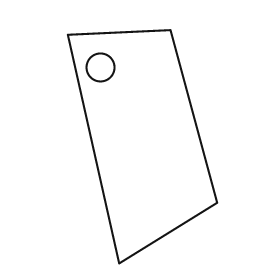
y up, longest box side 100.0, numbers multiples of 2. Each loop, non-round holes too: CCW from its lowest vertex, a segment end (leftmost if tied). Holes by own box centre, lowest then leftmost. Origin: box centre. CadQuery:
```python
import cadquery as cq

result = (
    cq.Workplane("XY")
    .moveTo(-10.0, -50.0)
    .lineTo(32.0, -24.0)
    .lineTo(12.0, 50.0)
    .lineTo(-32.0, 48.0)
    .close()
    .moveTo(-18.0, 34.0)
    .circle(6.0)
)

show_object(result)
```